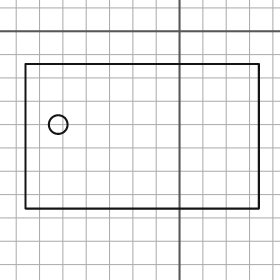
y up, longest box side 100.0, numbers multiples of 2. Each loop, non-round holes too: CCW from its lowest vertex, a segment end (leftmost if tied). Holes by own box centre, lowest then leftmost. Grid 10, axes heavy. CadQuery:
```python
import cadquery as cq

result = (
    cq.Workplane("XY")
    .moveTo(-66.0, -76.0)
    .lineTo(34.0, -76.0)
    .lineTo(34.0, -14.0)
    .lineTo(-66.0, -14.0)
    .close()
    .moveTo(-52.0, -40.0)
    .circle(4.0)
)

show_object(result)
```